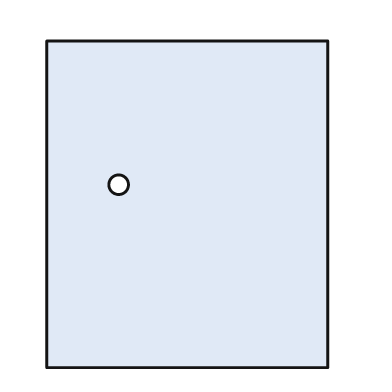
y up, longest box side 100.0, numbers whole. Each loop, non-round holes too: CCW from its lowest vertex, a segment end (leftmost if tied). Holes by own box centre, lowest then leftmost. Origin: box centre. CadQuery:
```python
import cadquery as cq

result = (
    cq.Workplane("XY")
    .moveTo(-43.0, -50.0)
    .lineTo(43.0, -50.0)
    .lineTo(43.0, 50.0)
    .lineTo(-43.0, 50.0)
    .close()
    .moveTo(-21.0, 6.0)
    .circle(3.0)
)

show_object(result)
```